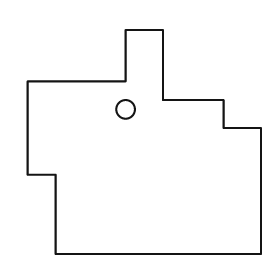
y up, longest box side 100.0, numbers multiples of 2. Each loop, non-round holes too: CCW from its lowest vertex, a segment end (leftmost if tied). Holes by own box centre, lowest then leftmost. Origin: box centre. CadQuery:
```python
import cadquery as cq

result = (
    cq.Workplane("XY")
    .moveTo(-38.0, -48.0)
    .lineTo(50.0, -48.0)
    .lineTo(50.0, 6.0)
    .lineTo(34.0, 6.0)
    .lineTo(34.0, 18.0)
    .lineTo(8.0, 18.0)
    .lineTo(8.0, 48.0)
    .lineTo(-8.0, 48.0)
    .lineTo(-8.0, 26.0)
    .lineTo(-50.0, 26.0)
    .lineTo(-50.0, -14.0)
    .lineTo(-38.0, -14.0)
    .close()
    .moveTo(-8.0, 14.0)
    .circle(4.0)
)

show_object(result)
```